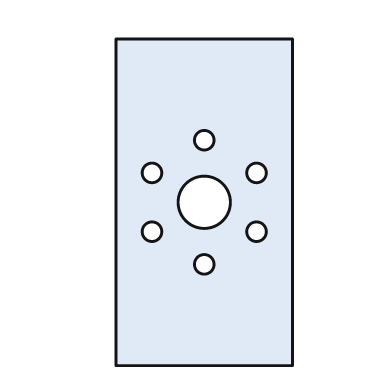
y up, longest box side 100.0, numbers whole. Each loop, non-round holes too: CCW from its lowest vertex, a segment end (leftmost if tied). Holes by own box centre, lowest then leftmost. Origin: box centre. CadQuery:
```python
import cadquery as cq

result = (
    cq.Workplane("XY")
    .moveTo(-27.0, -50.0)
    .lineTo(27.0, -50.0)
    .lineTo(27.0, 50.0)
    .lineTo(-27.0, 50.0)
    .close()
    .moveTo(0.0, -19.0)
    .circle(3.0)
    .moveTo(-16.0, -9.0)
    .circle(3.0)
    .moveTo(16.0, -9.0)
    .circle(3.0)
    .moveTo(0.0, 0.0)
    .circle(8.0)
    .moveTo(-16.0, 9.0)
    .circle(3.0)
    .moveTo(16.0, 9.0)
    .circle(3.0)
    .moveTo(0.0, 19.0)
    .circle(3.0)
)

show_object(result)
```